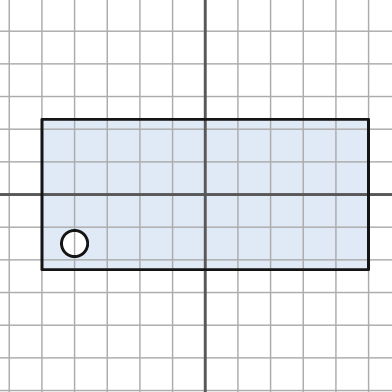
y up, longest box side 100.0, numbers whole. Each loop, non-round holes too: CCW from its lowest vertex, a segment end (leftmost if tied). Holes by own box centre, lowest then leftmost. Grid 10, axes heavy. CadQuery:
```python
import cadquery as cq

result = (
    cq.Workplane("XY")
    .moveTo(-50.0, -23.0)
    .lineTo(50.0, -23.0)
    .lineTo(50.0, 23.0)
    .lineTo(-50.0, 23.0)
    .close()
    .moveTo(-40.0, -15.0)
    .circle(4.0)
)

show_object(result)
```